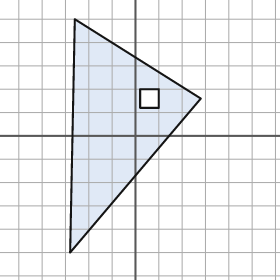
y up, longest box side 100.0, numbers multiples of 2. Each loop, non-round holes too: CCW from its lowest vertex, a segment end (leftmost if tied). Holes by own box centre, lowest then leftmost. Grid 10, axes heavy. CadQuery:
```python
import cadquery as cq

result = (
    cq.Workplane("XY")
    .moveTo(-28.0, -50.0)
    .lineTo(28.0, 16.0)
    .lineTo(-26.0, 50.0)
    .close()
    .moveTo(2.0, 12.0)
    .lineTo(10.0, 12.0)
    .lineTo(10.0, 20.0)
    .lineTo(2.0, 20.0)
    .close()
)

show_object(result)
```